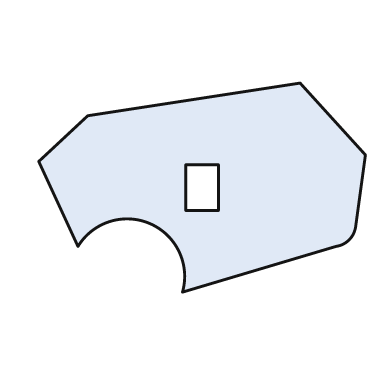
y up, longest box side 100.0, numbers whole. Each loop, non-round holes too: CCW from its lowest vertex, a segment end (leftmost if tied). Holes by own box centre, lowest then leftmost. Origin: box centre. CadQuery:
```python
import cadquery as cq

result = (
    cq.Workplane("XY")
    .moveTo(-6.0, -32.0)
    .lineTo(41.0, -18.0)
    .threePointArc((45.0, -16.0), (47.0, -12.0))
    .lineTo(50.0, 10.0)
    .lineTo(30.0, 32.0)
    .lineTo(-35.0, 22.0)
    .lineTo(-50.0, 8.0)
    .lineTo(-38.0, -18.0)
    .threePointArc((-16.0, -11.0), (-6.0, -32.0))
    .close()
    .moveTo(-5.0, -7.0)
    .lineTo(5.0, -7.0)
    .lineTo(5.0, 7.0)
    .lineTo(-5.0, 7.0)
    .close()
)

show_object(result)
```